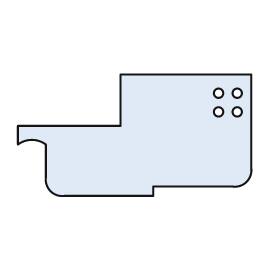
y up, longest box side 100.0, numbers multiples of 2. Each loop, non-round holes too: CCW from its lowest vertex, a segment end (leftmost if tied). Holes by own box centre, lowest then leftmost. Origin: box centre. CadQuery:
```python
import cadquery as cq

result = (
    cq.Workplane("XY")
    .moveTo(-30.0, -26.0)
    .lineTo(8.0, -26.0)
    .lineTo(8.0, -22.0)
    .lineTo(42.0, -22.0)
    .threePointArc((48.0, -20.0), (50.0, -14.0))
    .lineTo(50.0, 26.0)
    .lineTo(-6.0, 26.0)
    .lineTo(-6.0, 4.0)
    .lineTo(-50.0, 4.0)
    .lineTo(-50.0, -4.0)
    .threePointArc((-44.0, -2.0), (-38.0, -4.0))
    .lineTo(-38.0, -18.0)
    .threePointArc((-36.0, -24.0), (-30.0, -26.0))
    .close()
    .moveTo(36.0, 10.0)
    .circle(2.0)
    .moveTo(44.0, 10.0)
    .circle(2.0)
    .moveTo(36.0, 18.0)
    .circle(2.0)
    .moveTo(44.0, 18.0)
    .circle(2.0)
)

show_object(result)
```